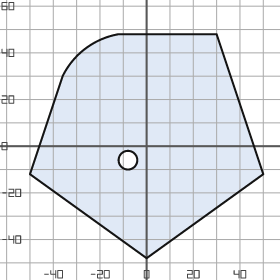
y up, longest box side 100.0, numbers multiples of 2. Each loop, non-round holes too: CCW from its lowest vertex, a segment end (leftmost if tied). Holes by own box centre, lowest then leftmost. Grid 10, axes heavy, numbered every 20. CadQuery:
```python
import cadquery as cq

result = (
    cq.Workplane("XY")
    .moveTo(0.0, -48.0)
    .lineTo(50.0, -12.0)
    .lineTo(30.0, 48.0)
    .lineTo(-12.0, 48.0)
    .threePointArc((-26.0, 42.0), (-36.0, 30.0))
    .lineTo(-50.0, -12.0)
    .close()
    .moveTo(-8.0, -6.0)
    .circle(4.0)
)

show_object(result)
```